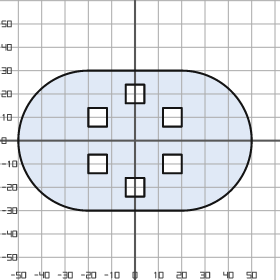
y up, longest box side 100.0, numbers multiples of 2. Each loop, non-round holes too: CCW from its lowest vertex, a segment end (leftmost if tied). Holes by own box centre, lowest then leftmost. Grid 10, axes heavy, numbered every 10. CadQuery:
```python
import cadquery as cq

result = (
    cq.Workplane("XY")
    .moveTo(-20.0, -30.0)
    .lineTo(20.0, -30.0)
    .threePointArc((50.0, 0.0), (20.0, 30.0))
    .lineTo(-20.0, 30.0)
    .threePointArc((-50.0, 0.0), (-20.0, -30.0))
    .close()
    .moveTo(-4.0, -24.0)
    .lineTo(4.0, -24.0)
    .lineTo(4.0, -16.0)
    .lineTo(-4.0, -16.0)
    .close()
    .moveTo(-20.0, -14.0)
    .lineTo(-12.0, -14.0)
    .lineTo(-12.0, -6.0)
    .lineTo(-20.0, -6.0)
    .close()
    .moveTo(12.0, -14.0)
    .lineTo(20.0, -14.0)
    .lineTo(20.0, -6.0)
    .lineTo(12.0, -6.0)
    .close()
    .moveTo(-20.0, 6.0)
    .lineTo(-12.0, 6.0)
    .lineTo(-12.0, 14.0)
    .lineTo(-20.0, 14.0)
    .close()
    .moveTo(12.0, 6.0)
    .lineTo(20.0, 6.0)
    .lineTo(20.0, 14.0)
    .lineTo(12.0, 14.0)
    .close()
    .moveTo(-4.0, 16.0)
    .lineTo(4.0, 16.0)
    .lineTo(4.0, 24.0)
    .lineTo(-4.0, 24.0)
    .close()
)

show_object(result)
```